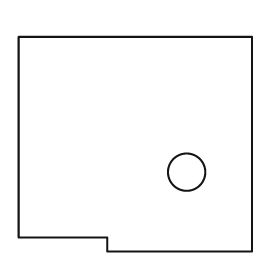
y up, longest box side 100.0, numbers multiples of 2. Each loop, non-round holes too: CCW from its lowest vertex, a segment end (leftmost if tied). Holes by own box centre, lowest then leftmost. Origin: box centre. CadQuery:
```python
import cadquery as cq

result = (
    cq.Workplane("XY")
    .moveTo(-12.0, -46.0)
    .lineTo(50.0, -46.0)
    .lineTo(50.0, 46.0)
    .lineTo(-50.0, 46.0)
    .lineTo(-50.0, -40.0)
    .lineTo(-12.0, -40.0)
    .close()
    .moveTo(22.0, -12.0)
    .circle(8.0)
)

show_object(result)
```